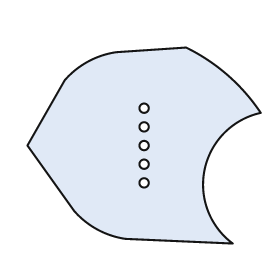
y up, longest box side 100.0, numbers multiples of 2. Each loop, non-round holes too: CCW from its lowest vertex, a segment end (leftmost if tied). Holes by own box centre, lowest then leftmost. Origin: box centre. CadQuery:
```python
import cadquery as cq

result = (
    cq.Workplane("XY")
    .moveTo(38.0, -42.0)
    .threePointArc((26.0, -10.0), (50.0, 14.0))
    .threePointArc((36.0, 30.0), (18.0, 42.0))
    .lineTo(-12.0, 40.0)
    .threePointArc((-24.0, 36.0), (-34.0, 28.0))
    .lineTo(-50.0, 0.0)
    .lineTo(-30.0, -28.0)
    .threePointArc((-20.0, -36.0), (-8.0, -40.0))
    .close()
    .moveTo(0.0, -16.0)
    .circle(2.0)
    .moveTo(0.0, -8.0)
    .circle(2.0)
    .moveTo(0.0, 0.0)
    .circle(2.0)
    .moveTo(0.0, 8.0)
    .circle(2.0)
    .moveTo(0.0, 16.0)
    .circle(2.0)
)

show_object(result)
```